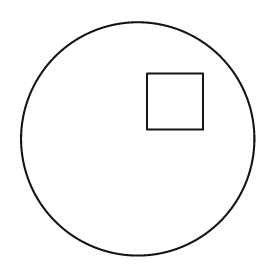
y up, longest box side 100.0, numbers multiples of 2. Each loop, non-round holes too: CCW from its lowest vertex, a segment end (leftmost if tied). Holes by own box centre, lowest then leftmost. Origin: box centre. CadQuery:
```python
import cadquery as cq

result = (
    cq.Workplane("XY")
    .moveTo(0.0, 0.0)
    .circle(50.0)
    .moveTo(4.0, 4.0)
    .lineTo(28.0, 4.0)
    .lineTo(28.0, 28.0)
    .lineTo(4.0, 28.0)
    .close()
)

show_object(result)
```